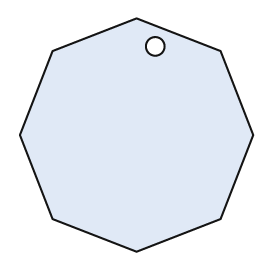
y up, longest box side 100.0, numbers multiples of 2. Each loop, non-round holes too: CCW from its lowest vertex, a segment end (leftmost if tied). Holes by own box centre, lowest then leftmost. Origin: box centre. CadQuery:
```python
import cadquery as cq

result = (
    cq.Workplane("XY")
    .moveTo(0.0, -50.0)
    .lineTo(36.0, -36.0)
    .lineTo(50.0, 0.0)
    .lineTo(36.0, 36.0)
    .lineTo(0.0, 50.0)
    .lineTo(-36.0, 36.0)
    .lineTo(-50.0, 0.0)
    .lineTo(-36.0, -36.0)
    .close()
    .moveTo(8.0, 38.0)
    .circle(4.0)
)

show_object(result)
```